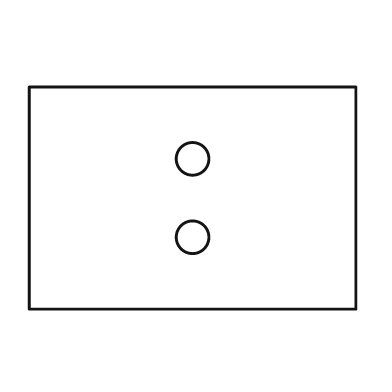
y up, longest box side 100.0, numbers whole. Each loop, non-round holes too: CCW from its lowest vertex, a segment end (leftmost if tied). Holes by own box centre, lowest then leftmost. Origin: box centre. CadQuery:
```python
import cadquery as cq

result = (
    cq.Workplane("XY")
    .moveTo(-50.0, -34.0)
    .lineTo(50.0, -34.0)
    .lineTo(50.0, 34.0)
    .lineTo(-50.0, 34.0)
    .close()
    .moveTo(0.0, -12.0)
    .circle(5.0)
    .moveTo(0.0, 12.0)
    .circle(5.0)
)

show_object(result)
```